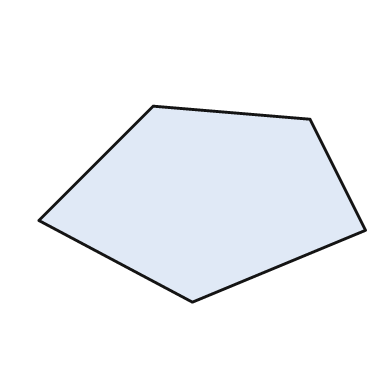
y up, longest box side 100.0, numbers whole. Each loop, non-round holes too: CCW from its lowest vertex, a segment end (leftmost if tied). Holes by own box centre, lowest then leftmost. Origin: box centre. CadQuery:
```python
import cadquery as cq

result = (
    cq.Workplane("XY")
    .moveTo(-3.0, -30.0)
    .lineTo(50.0, -8.0)
    .lineTo(33.0, 26.0)
    .lineTo(-15.0, 30.0)
    .lineTo(-50.0, -5.0)
    .close()
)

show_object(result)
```